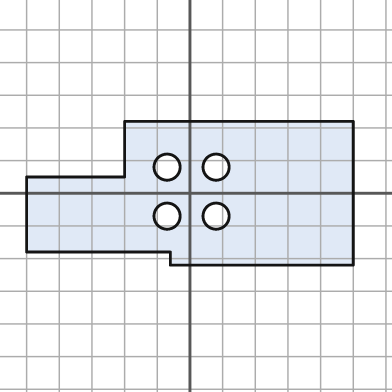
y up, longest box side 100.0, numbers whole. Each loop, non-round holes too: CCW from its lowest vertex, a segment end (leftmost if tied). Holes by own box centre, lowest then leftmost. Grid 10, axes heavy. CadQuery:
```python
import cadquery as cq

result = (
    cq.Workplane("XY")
    .moveTo(-6.0, -22.0)
    .lineTo(50.0, -22.0)
    .lineTo(50.0, 22.0)
    .lineTo(-20.0, 22.0)
    .lineTo(-20.0, 5.0)
    .lineTo(-50.0, 5.0)
    .lineTo(-50.0, -18.0)
    .lineTo(-6.0, -18.0)
    .close()
    .moveTo(-7.0, -7.0)
    .circle(4.0)
    .moveTo(8.0, -7.0)
    .circle(4.0)
    .moveTo(-7.0, 8.0)
    .circle(4.0)
    .moveTo(8.0, 8.0)
    .circle(4.0)
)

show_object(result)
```